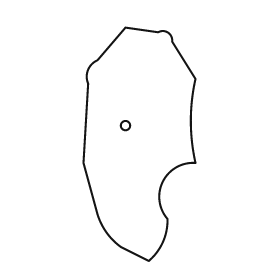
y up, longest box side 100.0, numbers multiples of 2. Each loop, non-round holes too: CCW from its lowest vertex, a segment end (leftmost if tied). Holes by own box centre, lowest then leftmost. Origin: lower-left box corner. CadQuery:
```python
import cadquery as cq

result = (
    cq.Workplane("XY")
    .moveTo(28.0, 0.0)
    .threePointArc((34.0, 8.0), (36.0, 18.0))
    .threePointArc((34.0, 34.0), (48.0, 42.0))
    .threePointArc((46.0, 60.0), (48.0, 78.0))
    .lineTo(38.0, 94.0)
    .threePointArc((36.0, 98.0), (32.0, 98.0))
    .lineTo(18.0, 100.0)
    .lineTo(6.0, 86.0)
    .threePointArc((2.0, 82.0), (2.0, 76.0))
    .lineTo(0.0, 42.0)
    .lineTo(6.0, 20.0)
    .threePointArc((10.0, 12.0), (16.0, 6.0))
    .close()
    .moveTo(18.0, 58.0)
    .circle(2.0)
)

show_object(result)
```